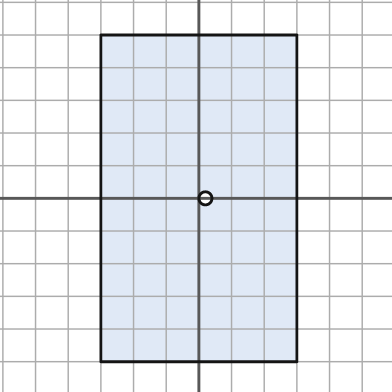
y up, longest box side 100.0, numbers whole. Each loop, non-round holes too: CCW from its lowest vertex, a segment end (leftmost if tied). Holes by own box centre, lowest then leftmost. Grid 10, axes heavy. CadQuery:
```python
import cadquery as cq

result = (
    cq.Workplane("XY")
    .moveTo(-30.0, -50.0)
    .lineTo(30.0, -50.0)
    .lineTo(30.0, 50.0)
    .lineTo(-30.0, 50.0)
    .close()
    .moveTo(2.0, 0.0)
    .circle(2.0)
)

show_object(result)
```